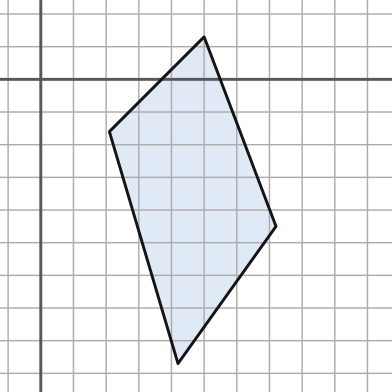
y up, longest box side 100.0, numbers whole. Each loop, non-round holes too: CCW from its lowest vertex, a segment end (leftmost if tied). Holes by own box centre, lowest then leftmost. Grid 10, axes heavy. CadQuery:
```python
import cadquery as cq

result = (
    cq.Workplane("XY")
    .moveTo(42.0, -87.0)
    .lineTo(72.0, -45.0)
    .lineTo(50.0, 13.0)
    .lineTo(21.0, -16.0)
    .close()
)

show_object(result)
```